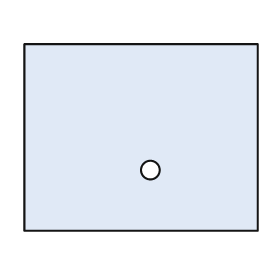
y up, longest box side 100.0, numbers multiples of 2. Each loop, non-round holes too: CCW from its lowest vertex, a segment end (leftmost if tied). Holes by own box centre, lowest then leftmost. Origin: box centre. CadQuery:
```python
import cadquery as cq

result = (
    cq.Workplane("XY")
    .moveTo(-50.0, -40.0)
    .lineTo(50.0, -40.0)
    .lineTo(50.0, 40.0)
    .lineTo(-50.0, 40.0)
    .close()
    .moveTo(4.0, -14.0)
    .circle(4.0)
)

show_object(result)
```